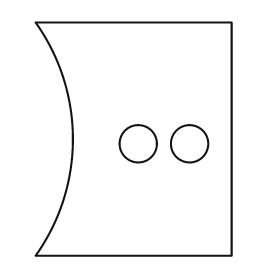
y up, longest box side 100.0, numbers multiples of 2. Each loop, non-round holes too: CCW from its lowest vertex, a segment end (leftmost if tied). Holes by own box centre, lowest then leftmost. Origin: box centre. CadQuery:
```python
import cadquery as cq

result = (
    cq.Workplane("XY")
    .moveTo(-42.0, -50.0)
    .lineTo(42.0, -50.0)
    .lineTo(42.0, 50.0)
    .lineTo(-42.0, 50.0)
    .threePointArc((-26.0, 0.0), (-42.0, -50.0))
    .close()
    .moveTo(2.0, -2.0)
    .circle(8.0)
    .moveTo(24.0, -2.0)
    .circle(8.0)
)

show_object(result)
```